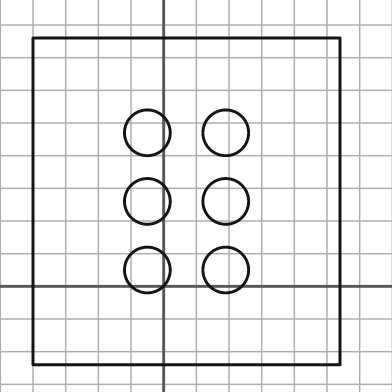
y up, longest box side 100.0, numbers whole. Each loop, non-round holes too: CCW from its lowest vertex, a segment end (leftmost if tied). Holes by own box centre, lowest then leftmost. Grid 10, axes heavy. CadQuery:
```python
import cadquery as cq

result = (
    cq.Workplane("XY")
    .moveTo(-40.0, -24.0)
    .lineTo(54.0, -24.0)
    .lineTo(54.0, 76.0)
    .lineTo(-40.0, 76.0)
    .close()
    .moveTo(-5.0, 5.0)
    .circle(7.0)
    .moveTo(19.0, 5.0)
    .circle(7.0)
    .moveTo(-5.0, 26.0)
    .circle(7.0)
    .moveTo(19.0, 26.0)
    .circle(7.0)
    .moveTo(-5.0, 47.0)
    .circle(7.0)
    .moveTo(19.0, 47.0)
    .circle(7.0)
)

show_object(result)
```